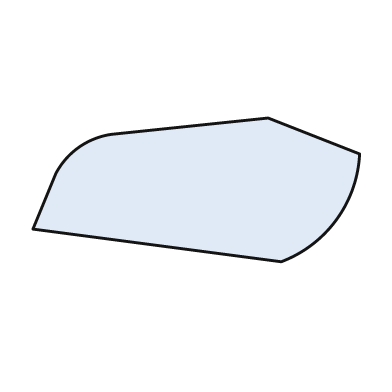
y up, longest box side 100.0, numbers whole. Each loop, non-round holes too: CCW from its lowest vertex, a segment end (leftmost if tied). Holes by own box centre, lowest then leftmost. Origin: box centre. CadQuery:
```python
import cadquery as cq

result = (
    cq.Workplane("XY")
    .moveTo(26.0, -22.0)
    .threePointArc((43.0, -9.0), (50.0, 11.0))
    .lineTo(22.0, 22.0)
    .lineTo(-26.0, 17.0)
    .threePointArc((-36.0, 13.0), (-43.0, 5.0))
    .lineTo(-50.0, -12.0)
    .close()
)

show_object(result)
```